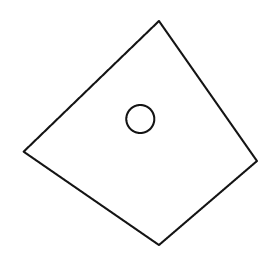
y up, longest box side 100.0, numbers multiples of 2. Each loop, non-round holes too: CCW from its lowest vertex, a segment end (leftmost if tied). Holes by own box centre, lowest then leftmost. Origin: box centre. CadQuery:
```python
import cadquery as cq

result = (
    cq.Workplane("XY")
    .moveTo(8.0, -48.0)
    .lineTo(50.0, -12.0)
    .lineTo(8.0, 48.0)
    .lineTo(-50.0, -8.0)
    .close()
    .moveTo(0.0, 6.0)
    .circle(6.0)
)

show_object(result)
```